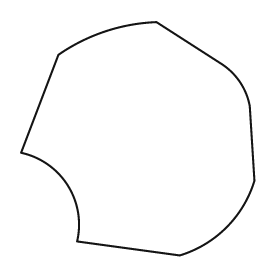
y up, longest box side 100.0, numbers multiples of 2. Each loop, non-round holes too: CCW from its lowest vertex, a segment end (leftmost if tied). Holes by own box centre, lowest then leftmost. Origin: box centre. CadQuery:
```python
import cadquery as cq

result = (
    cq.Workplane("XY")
    .moveTo(18.0, -50.0)
    .threePointArc((38.0, -38.0), (50.0, -18.0))
    .lineTo(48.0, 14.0)
    .threePointArc((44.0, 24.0), (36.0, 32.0))
    .lineTo(8.0, 50.0)
    .threePointArc((-14.0, 46.0), (-34.0, 36.0))
    .lineTo(-50.0, -6.0)
    .threePointArc((-30.0, -20.0), (-26.0, -44.0))
    .close()
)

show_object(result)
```